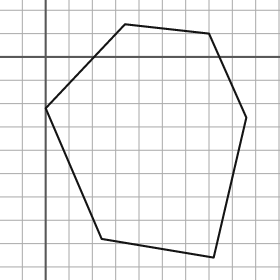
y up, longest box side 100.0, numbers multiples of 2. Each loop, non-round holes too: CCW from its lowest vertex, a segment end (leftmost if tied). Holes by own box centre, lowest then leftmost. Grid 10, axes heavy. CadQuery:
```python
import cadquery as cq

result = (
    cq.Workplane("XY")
    .moveTo(72.0, -86.0)
    .lineTo(86.0, -26.0)
    .lineTo(70.0, 10.0)
    .lineTo(34.0, 14.0)
    .lineTo(0.0, -22.0)
    .lineTo(24.0, -78.0)
    .close()
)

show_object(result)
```